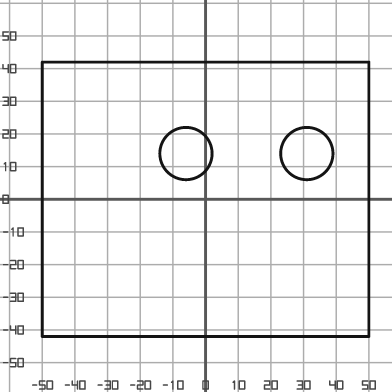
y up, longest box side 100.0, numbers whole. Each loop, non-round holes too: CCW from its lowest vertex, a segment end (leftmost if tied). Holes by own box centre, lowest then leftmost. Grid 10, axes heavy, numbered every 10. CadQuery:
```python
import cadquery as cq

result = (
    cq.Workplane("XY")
    .moveTo(-50.0, -42.0)
    .lineTo(50.0, -42.0)
    .lineTo(50.0, 42.0)
    .lineTo(-50.0, 42.0)
    .close()
    .moveTo(-6.0, 14.0)
    .circle(8.0)
    .moveTo(31.0, 14.0)
    .circle(8.0)
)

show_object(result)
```